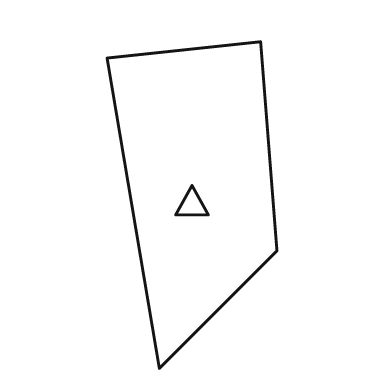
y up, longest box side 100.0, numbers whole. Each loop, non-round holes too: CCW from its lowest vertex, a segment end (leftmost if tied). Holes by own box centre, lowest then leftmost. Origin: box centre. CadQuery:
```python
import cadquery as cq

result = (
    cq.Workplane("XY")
    .moveTo(-10.0, -50.0)
    .lineTo(26.0, -14.0)
    .lineTo(21.0, 50.0)
    .lineTo(-26.0, 45.0)
    .close()
    .moveTo(-5.0, -3.0)
    .lineTo(5.0, -3.0)
    .lineTo(0.0, 6.0)
    .close()
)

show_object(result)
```